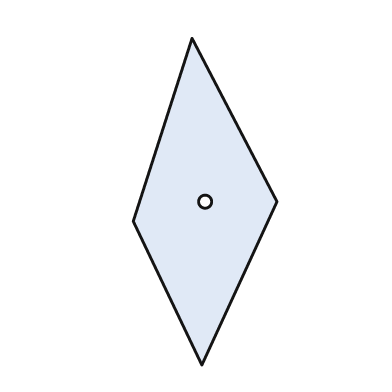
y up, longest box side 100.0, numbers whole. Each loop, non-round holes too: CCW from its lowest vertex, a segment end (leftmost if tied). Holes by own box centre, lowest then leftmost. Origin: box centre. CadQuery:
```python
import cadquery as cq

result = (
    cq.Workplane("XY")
    .moveTo(-1.0, -50.0)
    .lineTo(22.0, 0.0)
    .lineTo(-4.0, 50.0)
    .lineTo(-22.0, -6.0)
    .close()
    .moveTo(0.0, 0.0)
    .circle(2.0)
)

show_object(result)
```